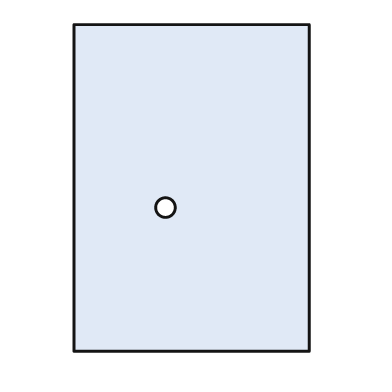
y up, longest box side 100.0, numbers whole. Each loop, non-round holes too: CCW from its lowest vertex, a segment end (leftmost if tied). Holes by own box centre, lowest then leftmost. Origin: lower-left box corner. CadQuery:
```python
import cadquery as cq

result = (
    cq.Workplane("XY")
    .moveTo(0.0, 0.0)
    .lineTo(72.0, 0.0)
    .lineTo(72.0, 100.0)
    .lineTo(0.0, 100.0)
    .close()
    .moveTo(28.0, 44.0)
    .circle(3.0)
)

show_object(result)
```